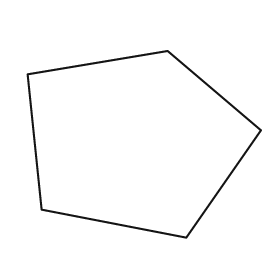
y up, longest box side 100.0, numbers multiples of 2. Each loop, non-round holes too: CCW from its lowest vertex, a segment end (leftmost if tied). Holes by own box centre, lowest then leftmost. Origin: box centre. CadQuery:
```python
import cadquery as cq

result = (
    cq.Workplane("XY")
    .moveTo(18.0, -40.0)
    .lineTo(50.0, 6.0)
    .lineTo(10.0, 40.0)
    .lineTo(-50.0, 30.0)
    .lineTo(-44.0, -28.0)
    .close()
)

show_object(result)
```